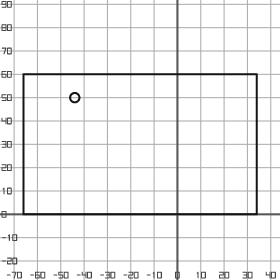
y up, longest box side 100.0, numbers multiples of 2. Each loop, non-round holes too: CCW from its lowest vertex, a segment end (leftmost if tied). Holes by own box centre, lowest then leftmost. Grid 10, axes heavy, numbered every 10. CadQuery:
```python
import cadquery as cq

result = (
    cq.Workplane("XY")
    .moveTo(-66.0, 0.0)
    .lineTo(34.0, 0.0)
    .lineTo(34.0, 60.0)
    .lineTo(-66.0, 60.0)
    .close()
    .moveTo(-44.0, 50.0)
    .circle(2.0)
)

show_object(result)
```